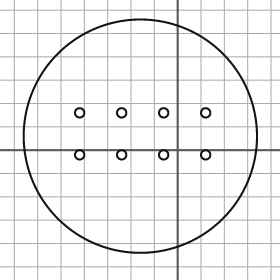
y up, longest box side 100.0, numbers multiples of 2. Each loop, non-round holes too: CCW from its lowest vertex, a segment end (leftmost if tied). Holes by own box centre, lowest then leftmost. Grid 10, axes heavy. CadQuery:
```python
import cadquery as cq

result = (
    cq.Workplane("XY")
    .moveTo(-16.0, 6.0)
    .circle(50.0)
    .moveTo(-42.0, -2.0)
    .circle(2.0)
    .moveTo(-24.0, -2.0)
    .circle(2.0)
    .moveTo(-6.0, -2.0)
    .circle(2.0)
    .moveTo(12.0, -2.0)
    .circle(2.0)
    .moveTo(-42.0, 16.0)
    .circle(2.0)
    .moveTo(-24.0, 16.0)
    .circle(2.0)
    .moveTo(-6.0, 16.0)
    .circle(2.0)
    .moveTo(12.0, 16.0)
    .circle(2.0)
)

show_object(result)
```